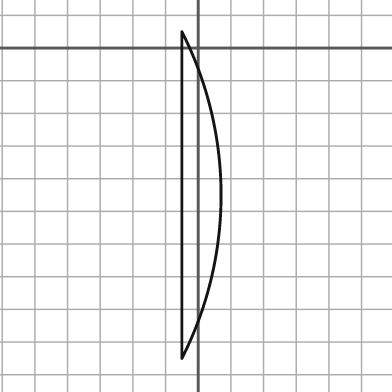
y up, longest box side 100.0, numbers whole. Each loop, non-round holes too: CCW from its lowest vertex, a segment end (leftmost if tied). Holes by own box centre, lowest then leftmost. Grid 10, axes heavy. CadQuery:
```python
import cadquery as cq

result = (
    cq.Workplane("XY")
    .moveTo(-5.0, -95.0)
    .threePointArc((7.0, -45.0), (-5.0, 5.0))
    .close()
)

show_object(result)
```